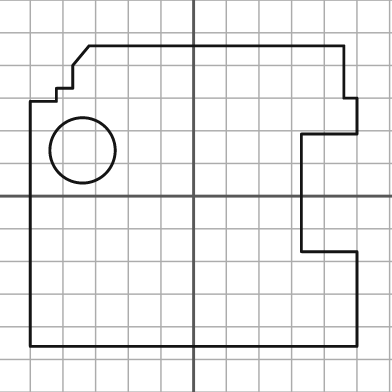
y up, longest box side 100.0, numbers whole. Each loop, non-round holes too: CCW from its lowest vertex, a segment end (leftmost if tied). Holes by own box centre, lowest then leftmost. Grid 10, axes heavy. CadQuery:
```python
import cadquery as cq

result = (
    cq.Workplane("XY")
    .moveTo(-50.0, -46.0)
    .lineTo(50.0, -46.0)
    .lineTo(50.0, -17.0)
    .lineTo(33.0, -17.0)
    .lineTo(33.0, 19.0)
    .lineTo(50.0, 19.0)
    .lineTo(50.0, 30.0)
    .lineTo(46.0, 30.0)
    .lineTo(46.0, 46.0)
    .lineTo(-32.0, 46.0)
    .lineTo(-37.0, 40.0)
    .lineTo(-37.0, 33.0)
    .lineTo(-42.0, 33.0)
    .lineTo(-42.0, 29.0)
    .lineTo(-50.0, 29.0)
    .close()
    .moveTo(-34.0, 14.0)
    .circle(10.0)
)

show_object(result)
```